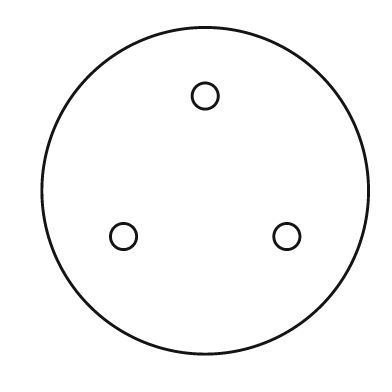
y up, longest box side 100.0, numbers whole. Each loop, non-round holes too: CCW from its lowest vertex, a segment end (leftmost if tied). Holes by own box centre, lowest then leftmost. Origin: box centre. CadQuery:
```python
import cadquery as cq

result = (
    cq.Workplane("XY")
    .moveTo(0.0, 0.0)
    .circle(50.0)
    .moveTo(-25.0, -14.0)
    .circle(4.0)
    .moveTo(25.0, -14.0)
    .circle(4.0)
    .moveTo(0.0, 29.0)
    .circle(4.0)
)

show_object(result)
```